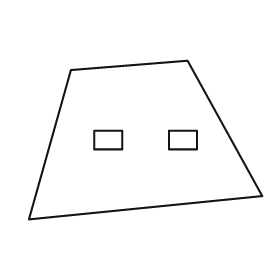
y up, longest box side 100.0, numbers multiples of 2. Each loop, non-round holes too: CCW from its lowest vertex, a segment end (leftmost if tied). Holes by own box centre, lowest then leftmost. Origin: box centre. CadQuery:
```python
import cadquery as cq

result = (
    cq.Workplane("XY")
    .moveTo(-50.0, -34.0)
    .lineTo(50.0, -24.0)
    .lineTo(18.0, 34.0)
    .lineTo(-32.0, 30.0)
    .close()
    .moveTo(-22.0, -4.0)
    .lineTo(-10.0, -4.0)
    .lineTo(-10.0, 4.0)
    .lineTo(-22.0, 4.0)
    .close()
    .moveTo(10.0, -4.0)
    .lineTo(22.0, -4.0)
    .lineTo(22.0, 4.0)
    .lineTo(10.0, 4.0)
    .close()
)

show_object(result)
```